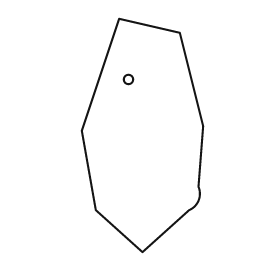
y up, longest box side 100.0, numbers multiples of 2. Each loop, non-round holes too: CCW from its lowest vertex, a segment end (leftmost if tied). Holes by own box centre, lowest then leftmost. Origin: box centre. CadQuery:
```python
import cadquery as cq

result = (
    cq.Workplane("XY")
    .moveTo(0.0, -50.0)
    .lineTo(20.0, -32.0)
    .threePointArc((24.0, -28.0), (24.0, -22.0))
    .lineTo(26.0, 4.0)
    .lineTo(16.0, 44.0)
    .lineTo(-10.0, 50.0)
    .lineTo(-26.0, 2.0)
    .lineTo(-20.0, -32.0)
    .close()
    .moveTo(-6.0, 24.0)
    .circle(2.0)
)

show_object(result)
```